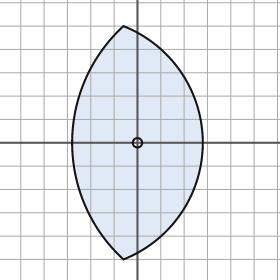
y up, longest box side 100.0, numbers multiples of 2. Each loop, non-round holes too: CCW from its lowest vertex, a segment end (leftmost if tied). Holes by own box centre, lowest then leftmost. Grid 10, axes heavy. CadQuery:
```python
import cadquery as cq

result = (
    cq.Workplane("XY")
    .moveTo(-6.0, -50.0)
    .threePointArc((28.0, 0.0), (-6.0, 50.0))
    .threePointArc((-28.0, 0.0), (-6.0, -50.0))
    .close()
    .moveTo(0.0, 0.0)
    .circle(2.0)
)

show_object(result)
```